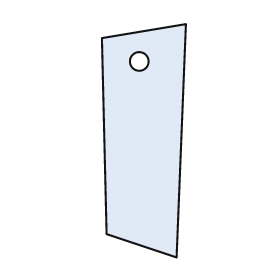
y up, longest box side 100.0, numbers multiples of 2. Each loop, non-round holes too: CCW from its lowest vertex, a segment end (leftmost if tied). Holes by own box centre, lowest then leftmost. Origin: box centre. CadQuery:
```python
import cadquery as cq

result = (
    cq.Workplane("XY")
    .moveTo(14.0, -50.0)
    .lineTo(18.0, 50.0)
    .lineTo(-18.0, 44.0)
    .lineTo(-16.0, -40.0)
    .close()
    .moveTo(-2.0, 34.0)
    .circle(4.0)
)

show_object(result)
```